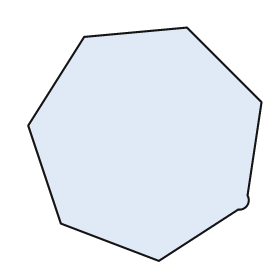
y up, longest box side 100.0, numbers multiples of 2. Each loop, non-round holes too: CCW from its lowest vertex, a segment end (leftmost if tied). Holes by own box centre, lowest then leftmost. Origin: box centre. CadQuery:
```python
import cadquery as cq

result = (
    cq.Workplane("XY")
    .moveTo(6.0, -50.0)
    .lineTo(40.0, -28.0)
    .threePointArc((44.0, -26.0), (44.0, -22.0))
    .lineTo(50.0, 18.0)
    .lineTo(18.0, 50.0)
    .lineTo(-26.0, 46.0)
    .lineTo(-50.0, 8.0)
    .lineTo(-36.0, -34.0)
    .close()
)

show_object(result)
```